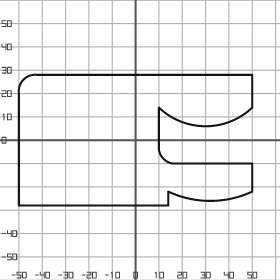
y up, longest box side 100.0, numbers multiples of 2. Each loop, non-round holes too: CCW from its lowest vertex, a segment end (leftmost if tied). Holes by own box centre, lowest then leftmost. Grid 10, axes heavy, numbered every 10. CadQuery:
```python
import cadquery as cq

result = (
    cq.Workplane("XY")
    .moveTo(-50.0, -28.0)
    .lineTo(14.0, -28.0)
    .lineTo(14.0, -22.0)
    .threePointArc((32.0, -26.0), (50.0, -22.0))
    .lineTo(50.0, -10.0)
    .lineTo(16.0, -10.0)
    .threePointArc((12.0, -8.0), (10.0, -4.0))
    .lineTo(10.0, 14.0)
    .threePointArc((30.0, 6.0), (50.0, 14.0))
    .lineTo(50.0, 28.0)
    .lineTo(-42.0, 28.0)
    .threePointArc((-48.0, 26.0), (-50.0, 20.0))
    .close()
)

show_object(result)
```